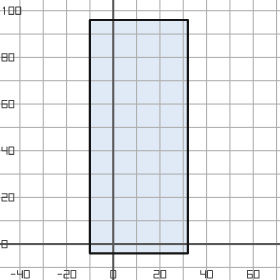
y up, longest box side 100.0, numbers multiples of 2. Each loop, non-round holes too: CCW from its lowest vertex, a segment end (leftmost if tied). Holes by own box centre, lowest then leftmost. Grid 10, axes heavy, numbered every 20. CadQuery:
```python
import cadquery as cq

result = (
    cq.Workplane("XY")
    .moveTo(-10.0, -4.0)
    .lineTo(32.0, -4.0)
    .lineTo(32.0, 96.0)
    .lineTo(-10.0, 96.0)
    .close()
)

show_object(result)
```